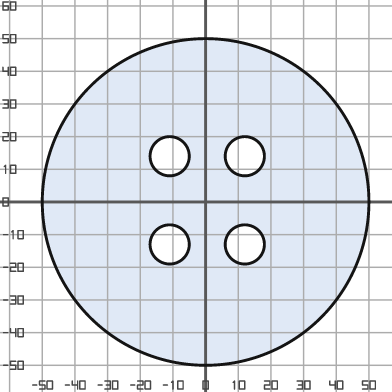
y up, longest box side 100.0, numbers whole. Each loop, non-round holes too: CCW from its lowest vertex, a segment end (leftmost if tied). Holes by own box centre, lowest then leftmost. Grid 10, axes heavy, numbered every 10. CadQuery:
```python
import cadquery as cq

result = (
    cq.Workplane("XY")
    .moveTo(0.0, 0.0)
    .circle(50.0)
    .moveTo(-11.0, -13.0)
    .circle(6.0)
    .moveTo(12.0, -13.0)
    .circle(6.0)
    .moveTo(-11.0, 14.0)
    .circle(6.0)
    .moveTo(12.0, 14.0)
    .circle(6.0)
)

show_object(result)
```